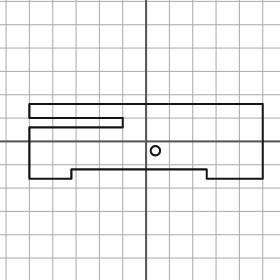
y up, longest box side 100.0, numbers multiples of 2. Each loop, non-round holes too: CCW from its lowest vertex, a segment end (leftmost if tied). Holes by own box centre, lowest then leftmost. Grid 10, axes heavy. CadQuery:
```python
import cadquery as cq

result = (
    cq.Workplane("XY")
    .moveTo(-50.0, -16.0)
    .lineTo(-32.0, -16.0)
    .lineTo(-32.0, -12.0)
    .lineTo(26.0, -12.0)
    .lineTo(26.0, -16.0)
    .lineTo(50.0, -16.0)
    .lineTo(50.0, 16.0)
    .lineTo(-50.0, 16.0)
    .lineTo(-50.0, 10.0)
    .lineTo(-10.0, 10.0)
    .lineTo(-10.0, 6.0)
    .lineTo(-50.0, 6.0)
    .close()
    .moveTo(4.0, -4.0)
    .circle(2.0)
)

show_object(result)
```